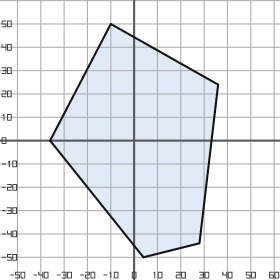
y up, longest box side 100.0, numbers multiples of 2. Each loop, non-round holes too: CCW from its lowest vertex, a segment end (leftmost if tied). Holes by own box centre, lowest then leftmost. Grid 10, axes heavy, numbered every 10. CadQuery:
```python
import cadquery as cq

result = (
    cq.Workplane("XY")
    .moveTo(4.0, -50.0)
    .lineTo(28.0, -44.0)
    .lineTo(36.0, 24.0)
    .lineTo(-10.0, 50.0)
    .lineTo(-36.0, 0.0)
    .close()
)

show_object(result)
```